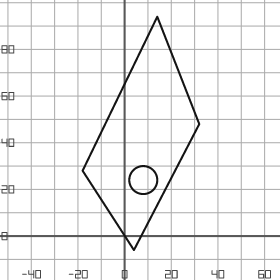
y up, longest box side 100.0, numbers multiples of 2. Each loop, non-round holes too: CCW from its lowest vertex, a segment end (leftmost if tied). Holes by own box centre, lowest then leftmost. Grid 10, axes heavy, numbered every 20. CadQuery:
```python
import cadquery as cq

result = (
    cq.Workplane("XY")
    .moveTo(4.0, -6.0)
    .lineTo(32.0, 48.0)
    .lineTo(14.0, 94.0)
    .lineTo(-18.0, 28.0)
    .close()
    .moveTo(8.0, 24.0)
    .circle(6.0)
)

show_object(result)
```